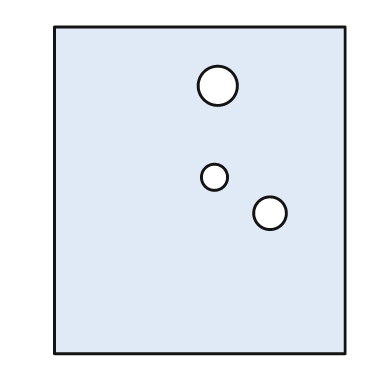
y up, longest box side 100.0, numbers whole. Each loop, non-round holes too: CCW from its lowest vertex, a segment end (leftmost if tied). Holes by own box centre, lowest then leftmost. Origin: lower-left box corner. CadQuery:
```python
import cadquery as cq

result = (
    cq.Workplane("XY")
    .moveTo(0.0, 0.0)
    .lineTo(89.0, 0.0)
    .lineTo(89.0, 100.0)
    .lineTo(0.0, 100.0)
    .close()
    .moveTo(66.0, 43.0)
    .circle(5.0)
    .moveTo(49.0, 54.0)
    .circle(4.0)
    .moveTo(50.0, 82.0)
    .circle(6.0)
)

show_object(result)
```